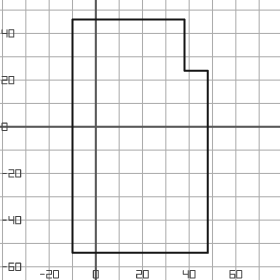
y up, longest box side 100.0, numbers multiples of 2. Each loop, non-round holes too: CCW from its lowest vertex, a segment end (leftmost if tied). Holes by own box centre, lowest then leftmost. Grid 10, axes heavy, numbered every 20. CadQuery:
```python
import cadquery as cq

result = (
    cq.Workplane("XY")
    .moveTo(-10.0, -54.0)
    .lineTo(48.0, -54.0)
    .lineTo(48.0, 24.0)
    .lineTo(38.0, 24.0)
    .lineTo(38.0, 46.0)
    .lineTo(-10.0, 46.0)
    .close()
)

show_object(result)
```